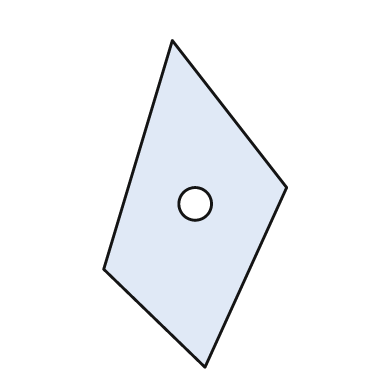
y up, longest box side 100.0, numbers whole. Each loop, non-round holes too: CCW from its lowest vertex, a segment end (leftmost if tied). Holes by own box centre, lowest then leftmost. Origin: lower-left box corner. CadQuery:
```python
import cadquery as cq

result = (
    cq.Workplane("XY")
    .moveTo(31.0, 0.0)
    .lineTo(56.0, 55.0)
    .lineTo(21.0, 100.0)
    .lineTo(0.0, 30.0)
    .close()
    .moveTo(28.0, 50.0)
    .circle(5.0)
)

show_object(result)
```